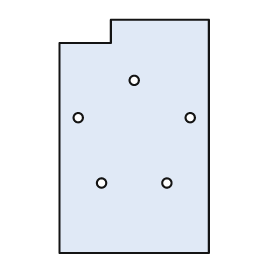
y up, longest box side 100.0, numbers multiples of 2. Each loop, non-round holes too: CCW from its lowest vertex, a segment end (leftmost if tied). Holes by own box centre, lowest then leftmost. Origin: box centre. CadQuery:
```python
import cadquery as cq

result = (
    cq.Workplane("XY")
    .moveTo(-32.0, -50.0)
    .lineTo(32.0, -50.0)
    .lineTo(32.0, 50.0)
    .lineTo(-10.0, 50.0)
    .lineTo(-10.0, 40.0)
    .lineTo(-32.0, 40.0)
    .close()
    .moveTo(-14.0, -20.0)
    .circle(2.0)
    .moveTo(14.0, -20.0)
    .circle(2.0)
    .moveTo(-24.0, 8.0)
    .circle(2.0)
    .moveTo(24.0, 8.0)
    .circle(2.0)
    .moveTo(0.0, 24.0)
    .circle(2.0)
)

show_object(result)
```